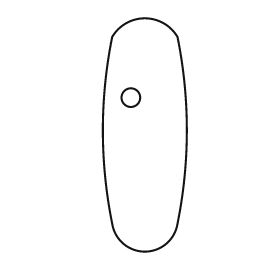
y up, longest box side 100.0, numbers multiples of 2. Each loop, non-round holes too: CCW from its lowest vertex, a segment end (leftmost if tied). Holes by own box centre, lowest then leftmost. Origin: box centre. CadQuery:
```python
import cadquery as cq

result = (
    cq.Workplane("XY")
    .moveTo(-14.0, -38.0)
    .threePointArc((0.0, -50.0), (14.0, -38.0))
    .threePointArc((18.0, 2.0), (14.0, 42.0))
    .threePointArc((0.0, 50.0), (-14.0, 42.0))
    .threePointArc((-18.0, 2.0), (-14.0, -38.0))
    .close()
    .moveTo(-6.0, 16.0)
    .circle(4.0)
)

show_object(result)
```